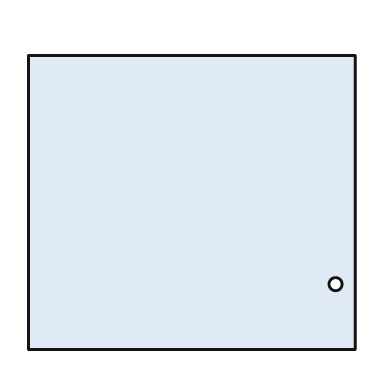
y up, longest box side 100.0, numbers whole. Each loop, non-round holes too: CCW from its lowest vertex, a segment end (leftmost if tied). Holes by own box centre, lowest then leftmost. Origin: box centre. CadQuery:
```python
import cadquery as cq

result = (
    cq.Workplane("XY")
    .moveTo(-50.0, -45.0)
    .lineTo(50.0, -45.0)
    .lineTo(50.0, 45.0)
    .lineTo(-50.0, 45.0)
    .close()
    .moveTo(44.0, -25.0)
    .circle(2.0)
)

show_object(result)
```